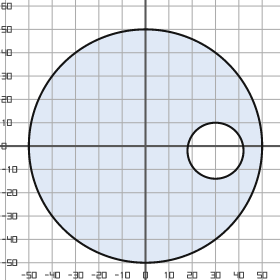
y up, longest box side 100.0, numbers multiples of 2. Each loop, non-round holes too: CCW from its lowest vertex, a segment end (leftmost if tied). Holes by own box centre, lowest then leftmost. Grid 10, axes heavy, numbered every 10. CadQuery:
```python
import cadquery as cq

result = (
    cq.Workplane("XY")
    .moveTo(0.0, 0.0)
    .circle(50.0)
    .moveTo(30.0, -2.0)
    .circle(12.0)
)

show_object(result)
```